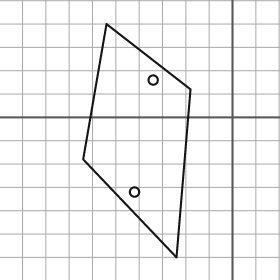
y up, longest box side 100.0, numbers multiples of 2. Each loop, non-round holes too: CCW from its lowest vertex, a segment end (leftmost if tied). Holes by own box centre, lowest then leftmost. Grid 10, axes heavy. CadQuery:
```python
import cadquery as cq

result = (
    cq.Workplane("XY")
    .moveTo(-24.0, -60.0)
    .lineTo(-18.0, 12.0)
    .lineTo(-54.0, 40.0)
    .lineTo(-64.0, -18.0)
    .close()
    .moveTo(-42.0, -32.0)
    .circle(2.0)
    .moveTo(-34.0, 16.0)
    .circle(2.0)
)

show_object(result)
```